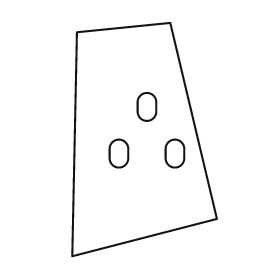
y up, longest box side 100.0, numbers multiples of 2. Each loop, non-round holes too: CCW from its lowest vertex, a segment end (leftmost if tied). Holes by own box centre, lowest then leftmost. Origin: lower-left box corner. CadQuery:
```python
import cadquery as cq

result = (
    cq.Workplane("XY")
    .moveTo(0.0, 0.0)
    .lineTo(62.0, 16.0)
    .lineTo(42.0, 100.0)
    .lineTo(2.0, 96.0)
    .close()
    .moveTo(16.0, 42.0)
    .threePointArc((20.0, 38.0), (24.0, 42.0))
    .lineTo(24.0, 46.0)
    .threePointArc((20.0, 50.0), (16.0, 46.0))
    .close()
    .moveTo(40.0, 42.0)
    .threePointArc((44.0, 38.0), (48.0, 42.0))
    .lineTo(48.0, 46.0)
    .threePointArc((44.0, 50.0), (40.0, 46.0))
    .close()
    .moveTo(28.0, 62.0)
    .threePointArc((32.0, 58.0), (36.0, 62.0))
    .lineTo(36.0, 66.0)
    .threePointArc((32.0, 70.0), (28.0, 66.0))
    .close()
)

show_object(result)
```